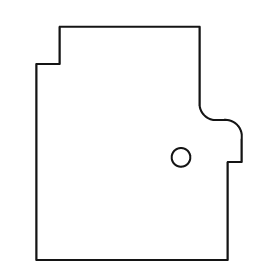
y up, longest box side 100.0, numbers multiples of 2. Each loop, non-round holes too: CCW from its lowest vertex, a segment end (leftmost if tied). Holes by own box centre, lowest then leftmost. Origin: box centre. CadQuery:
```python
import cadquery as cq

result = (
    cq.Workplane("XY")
    .moveTo(-44.0, -50.0)
    .lineTo(38.0, -50.0)
    .lineTo(38.0, -8.0)
    .lineTo(44.0, -8.0)
    .lineTo(44.0, 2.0)
    .threePointArc((42.0, 8.0), (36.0, 10.0))
    .lineTo(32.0, 10.0)
    .threePointArc((28.0, 12.0), (26.0, 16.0))
    .lineTo(26.0, 50.0)
    .lineTo(-34.0, 50.0)
    .lineTo(-34.0, 34.0)
    .lineTo(-44.0, 34.0)
    .close()
    .moveTo(18.0, -6.0)
    .circle(4.0)
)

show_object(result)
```